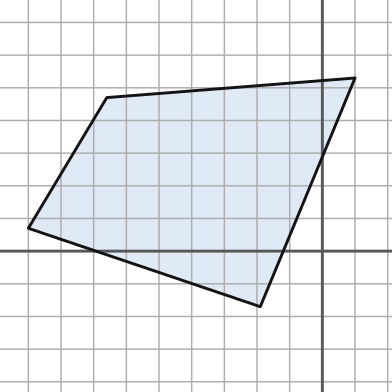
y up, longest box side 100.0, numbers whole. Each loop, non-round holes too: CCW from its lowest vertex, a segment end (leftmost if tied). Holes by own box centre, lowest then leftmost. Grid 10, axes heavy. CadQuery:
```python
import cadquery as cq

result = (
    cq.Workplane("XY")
    .moveTo(-19.0, -17.0)
    .lineTo(10.0, 53.0)
    .lineTo(-66.0, 47.0)
    .lineTo(-90.0, 7.0)
    .close()
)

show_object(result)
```